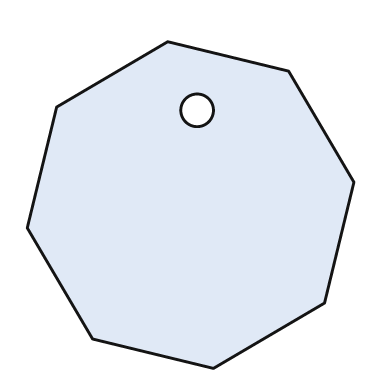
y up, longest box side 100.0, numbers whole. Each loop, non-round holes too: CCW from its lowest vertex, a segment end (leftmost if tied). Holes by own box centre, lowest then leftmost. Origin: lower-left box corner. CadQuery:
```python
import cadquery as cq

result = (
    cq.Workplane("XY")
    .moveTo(57.0, 0.0)
    .lineTo(91.0, 20.0)
    .lineTo(100.0, 57.0)
    .lineTo(80.0, 91.0)
    .lineTo(43.0, 100.0)
    .lineTo(9.0, 80.0)
    .lineTo(0.0, 43.0)
    .lineTo(20.0, 9.0)
    .close()
    .moveTo(52.0, 79.0)
    .circle(5.0)
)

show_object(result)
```